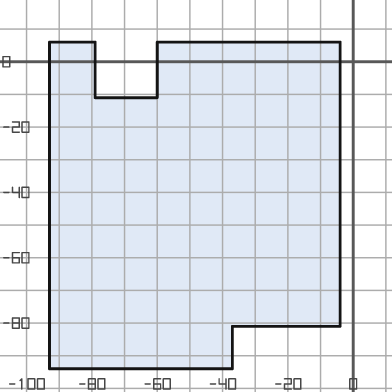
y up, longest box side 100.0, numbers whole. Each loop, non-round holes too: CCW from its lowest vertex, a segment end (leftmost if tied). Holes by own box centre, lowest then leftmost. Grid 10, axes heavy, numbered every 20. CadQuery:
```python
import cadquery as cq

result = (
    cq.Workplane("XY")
    .moveTo(-93.0, -94.0)
    .lineTo(-37.0, -94.0)
    .lineTo(-37.0, -81.0)
    .lineTo(-4.0, -81.0)
    .lineTo(-4.0, 6.0)
    .lineTo(-60.0, 6.0)
    .lineTo(-60.0, -11.0)
    .lineTo(-79.0, -11.0)
    .lineTo(-79.0, 6.0)
    .lineTo(-93.0, 6.0)
    .close()
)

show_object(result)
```